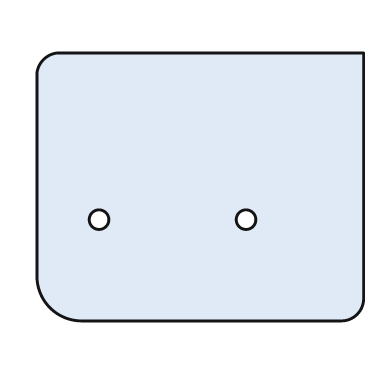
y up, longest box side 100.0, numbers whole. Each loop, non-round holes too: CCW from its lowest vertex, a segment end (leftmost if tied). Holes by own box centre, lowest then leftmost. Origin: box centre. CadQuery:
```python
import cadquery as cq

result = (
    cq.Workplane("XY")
    .moveTo(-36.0, -41.0)
    .lineTo(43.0, -41.0)
    .threePointArc((48.0, -39.0), (50.0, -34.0))
    .lineTo(50.0, 41.0)
    .lineTo(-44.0, 41.0)
    .threePointArc((-48.0, 39.0), (-50.0, 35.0))
    .lineTo(-50.0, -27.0)
    .threePointArc((-46.0, -37.0), (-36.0, -41.0))
    .close()
    .moveTo(-31.0, -10.0)
    .circle(3.0)
    .moveTo(14.0, -10.0)
    .circle(3.0)
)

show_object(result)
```